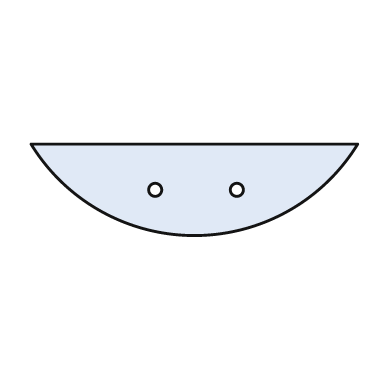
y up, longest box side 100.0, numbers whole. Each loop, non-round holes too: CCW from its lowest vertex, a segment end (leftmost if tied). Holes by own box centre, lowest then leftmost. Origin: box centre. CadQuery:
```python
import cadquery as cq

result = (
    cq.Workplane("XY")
    .moveTo(-50.0, 14.0)
    .threePointArc((0.0, -14.0), (50.0, 14.0))
    .close()
    .moveTo(-12.0, 0.0)
    .circle(2.0)
    .moveTo(13.0, 0.0)
    .circle(2.0)
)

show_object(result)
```